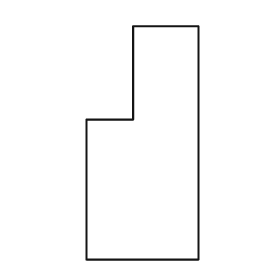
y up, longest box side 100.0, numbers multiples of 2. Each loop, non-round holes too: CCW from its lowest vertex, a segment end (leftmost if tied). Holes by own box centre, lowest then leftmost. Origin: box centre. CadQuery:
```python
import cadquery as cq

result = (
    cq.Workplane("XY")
    .moveTo(-24.0, -50.0)
    .lineTo(24.0, -50.0)
    .lineTo(24.0, 50.0)
    .lineTo(-4.0, 50.0)
    .lineTo(-4.0, 10.0)
    .lineTo(-24.0, 10.0)
    .close()
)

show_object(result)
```